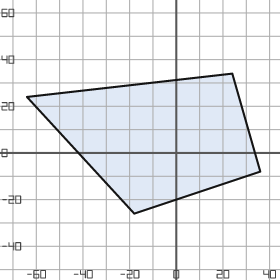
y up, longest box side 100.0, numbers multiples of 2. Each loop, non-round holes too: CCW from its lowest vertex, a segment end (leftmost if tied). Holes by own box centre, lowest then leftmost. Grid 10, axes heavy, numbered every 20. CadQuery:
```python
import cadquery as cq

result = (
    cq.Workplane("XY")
    .moveTo(-18.0, -26.0)
    .lineTo(36.0, -8.0)
    .lineTo(24.0, 34.0)
    .lineTo(-64.0, 24.0)
    .close()
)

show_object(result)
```